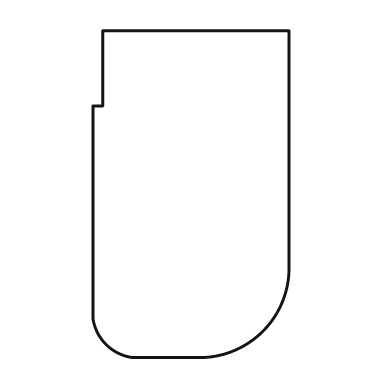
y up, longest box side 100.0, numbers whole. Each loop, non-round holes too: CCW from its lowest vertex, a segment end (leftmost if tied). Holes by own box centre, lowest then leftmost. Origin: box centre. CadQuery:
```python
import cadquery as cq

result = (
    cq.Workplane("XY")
    .moveTo(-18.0, -50.0)
    .lineTo(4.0, -50.0)
    .threePointArc((22.0, -42.0), (30.0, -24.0))
    .lineTo(30.0, 50.0)
    .lineTo(-27.0, 50.0)
    .lineTo(-27.0, 27.0)
    .lineTo(-30.0, 27.0)
    .lineTo(-30.0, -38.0)
    .threePointArc((-26.0, -46.0), (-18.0, -50.0))
    .close()
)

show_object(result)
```